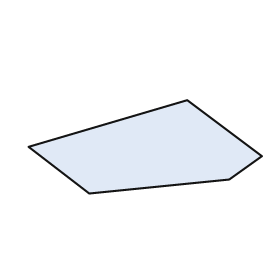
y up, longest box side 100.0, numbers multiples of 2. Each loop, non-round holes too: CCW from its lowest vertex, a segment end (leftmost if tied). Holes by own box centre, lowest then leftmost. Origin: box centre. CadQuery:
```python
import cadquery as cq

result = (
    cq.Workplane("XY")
    .moveTo(-24.0, -20.0)
    .lineTo(36.0, -14.0)
    .lineTo(50.0, -4.0)
    .lineTo(18.0, 20.0)
    .lineTo(-50.0, 0.0)
    .close()
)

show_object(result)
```